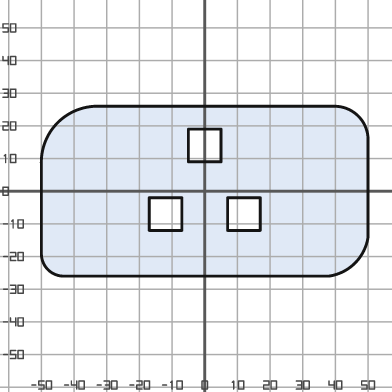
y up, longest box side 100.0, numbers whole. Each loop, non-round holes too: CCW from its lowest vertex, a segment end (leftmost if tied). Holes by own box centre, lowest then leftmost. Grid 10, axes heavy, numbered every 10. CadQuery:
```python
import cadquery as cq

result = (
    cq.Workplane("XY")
    .moveTo(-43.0, -26.0)
    .lineTo(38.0, -26.0)
    .threePointArc((46.0, -22.0), (50.0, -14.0))
    .lineTo(50.0, 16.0)
    .threePointArc((47.0, 23.0), (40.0, 26.0))
    .lineTo(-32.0, 26.0)
    .threePointArc((-45.0, 21.0), (-50.0, 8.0))
    .lineTo(-50.0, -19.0)
    .threePointArc((-48.0, -24.0), (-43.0, -26.0))
    .close()
    .moveTo(-17.0, -12.0)
    .lineTo(-7.0, -12.0)
    .lineTo(-7.0, -2.0)
    .lineTo(-17.0, -2.0)
    .close()
    .moveTo(7.0, -12.0)
    .lineTo(17.0, -12.0)
    .lineTo(17.0, -2.0)
    .lineTo(7.0, -2.0)
    .close()
    .moveTo(-5.0, 9.0)
    .lineTo(5.0, 9.0)
    .lineTo(5.0, 19.0)
    .lineTo(-5.0, 19.0)
    .close()
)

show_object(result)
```